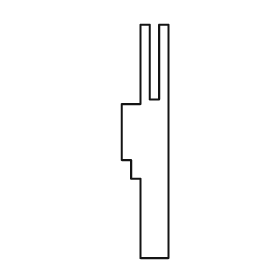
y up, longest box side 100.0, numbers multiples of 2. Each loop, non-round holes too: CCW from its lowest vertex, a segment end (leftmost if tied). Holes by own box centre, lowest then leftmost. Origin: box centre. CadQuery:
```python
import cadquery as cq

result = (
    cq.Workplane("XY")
    .moveTo(-2.0, -50.0)
    .lineTo(10.0, -50.0)
    .lineTo(10.0, 50.0)
    .lineTo(6.0, 50.0)
    .lineTo(6.0, 18.0)
    .lineTo(2.0, 18.0)
    .lineTo(2.0, 50.0)
    .lineTo(-2.0, 50.0)
    .lineTo(-2.0, 16.0)
    .lineTo(-10.0, 16.0)
    .lineTo(-10.0, -8.0)
    .lineTo(-6.0, -8.0)
    .lineTo(-6.0, -16.0)
    .lineTo(-2.0, -16.0)
    .close()
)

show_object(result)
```